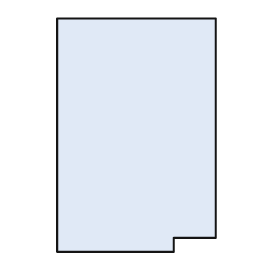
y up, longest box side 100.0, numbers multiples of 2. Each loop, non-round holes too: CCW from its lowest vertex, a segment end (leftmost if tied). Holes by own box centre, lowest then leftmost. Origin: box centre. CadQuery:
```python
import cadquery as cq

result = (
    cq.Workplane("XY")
    .moveTo(-34.0, -50.0)
    .lineTo(16.0, -50.0)
    .lineTo(16.0, -44.0)
    .lineTo(34.0, -44.0)
    .lineTo(34.0, 50.0)
    .lineTo(-34.0, 50.0)
    .close()
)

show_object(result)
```